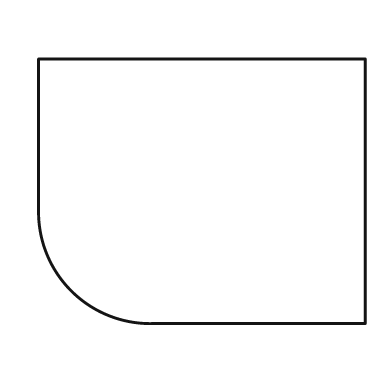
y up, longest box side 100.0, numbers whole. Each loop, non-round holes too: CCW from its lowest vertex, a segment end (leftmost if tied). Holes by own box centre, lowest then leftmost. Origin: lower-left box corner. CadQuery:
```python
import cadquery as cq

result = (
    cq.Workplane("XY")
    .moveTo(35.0, 0.0)
    .lineTo(100.0, 0.0)
    .lineTo(100.0, 81.0)
    .lineTo(0.0, 81.0)
    .lineTo(0.0, 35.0)
    .threePointArc((10.0, 10.0), (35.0, 0.0))
    .close()
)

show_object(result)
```